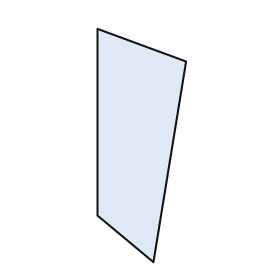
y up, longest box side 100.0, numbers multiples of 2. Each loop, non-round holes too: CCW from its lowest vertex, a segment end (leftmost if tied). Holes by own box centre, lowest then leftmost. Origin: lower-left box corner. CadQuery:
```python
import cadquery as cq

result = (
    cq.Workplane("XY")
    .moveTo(24.0, 0.0)
    .lineTo(38.0, 86.0)
    .lineTo(0.0, 100.0)
    .lineTo(0.0, 20.0)
    .close()
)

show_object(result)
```